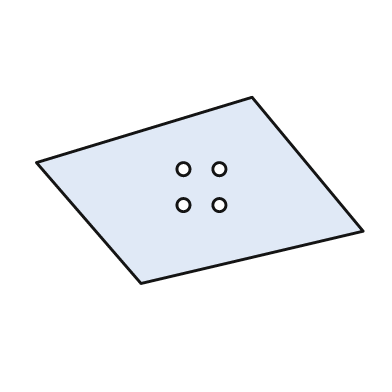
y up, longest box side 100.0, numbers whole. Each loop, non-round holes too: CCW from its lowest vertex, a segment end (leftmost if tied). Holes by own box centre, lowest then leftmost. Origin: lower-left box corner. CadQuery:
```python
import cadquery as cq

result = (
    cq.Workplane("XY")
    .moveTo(32.0, 0.0)
    .lineTo(100.0, 16.0)
    .lineTo(66.0, 57.0)
    .lineTo(0.0, 37.0)
    .close()
    .moveTo(45.0, 24.0)
    .circle(2.0)
    .moveTo(56.0, 24.0)
    .circle(2.0)
    .moveTo(45.0, 35.0)
    .circle(2.0)
    .moveTo(56.0, 35.0)
    .circle(2.0)
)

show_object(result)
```